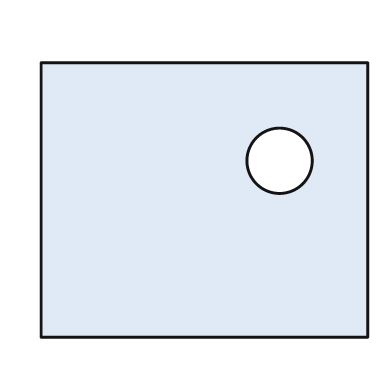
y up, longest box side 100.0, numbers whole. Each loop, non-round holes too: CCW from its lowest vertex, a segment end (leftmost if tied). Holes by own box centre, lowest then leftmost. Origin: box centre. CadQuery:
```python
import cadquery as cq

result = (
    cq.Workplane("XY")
    .moveTo(-50.0, -42.0)
    .lineTo(50.0, -42.0)
    .lineTo(50.0, 42.0)
    .lineTo(-50.0, 42.0)
    .close()
    .moveTo(23.0, 12.0)
    .circle(10.0)
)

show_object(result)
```